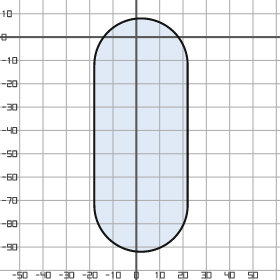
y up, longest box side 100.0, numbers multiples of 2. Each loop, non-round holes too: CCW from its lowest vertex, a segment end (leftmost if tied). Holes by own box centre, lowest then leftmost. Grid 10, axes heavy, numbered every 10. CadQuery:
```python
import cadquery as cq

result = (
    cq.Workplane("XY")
    .moveTo(-18.0, -72.0)
    .threePointArc((2.0, -92.0), (22.0, -72.0))
    .lineTo(22.0, -12.0)
    .threePointArc((2.0, 8.0), (-18.0, -12.0))
    .close()
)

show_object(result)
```